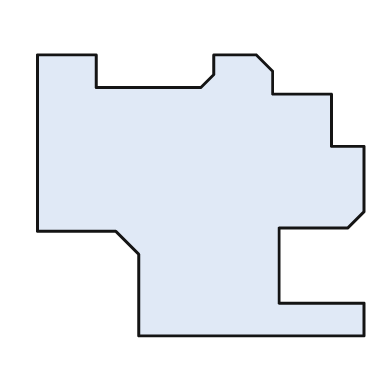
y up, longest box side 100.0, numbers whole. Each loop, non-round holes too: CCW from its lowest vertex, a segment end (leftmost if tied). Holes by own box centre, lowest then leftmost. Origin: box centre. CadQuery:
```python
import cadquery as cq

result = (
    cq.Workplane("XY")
    .moveTo(-19.0, -43.0)
    .lineTo(50.0, -43.0)
    .lineTo(50.0, -33.0)
    .lineTo(24.0, -33.0)
    .lineTo(24.0, -10.0)
    .lineTo(45.0, -10.0)
    .lineTo(50.0, -5.0)
    .lineTo(50.0, 15.0)
    .lineTo(40.0, 15.0)
    .lineTo(40.0, 31.0)
    .lineTo(22.0, 31.0)
    .lineTo(22.0, 38.0)
    .lineTo(17.0, 43.0)
    .lineTo(4.0, 43.0)
    .lineTo(4.0, 37.0)
    .lineTo(0.0, 33.0)
    .lineTo(-32.0, 33.0)
    .lineTo(-32.0, 43.0)
    .lineTo(-50.0, 43.0)
    .lineTo(-50.0, -11.0)
    .lineTo(-26.0, -11.0)
    .lineTo(-19.0, -18.0)
    .close()
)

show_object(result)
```